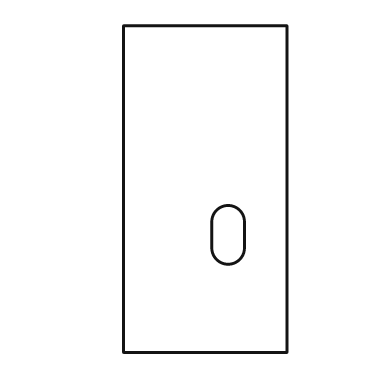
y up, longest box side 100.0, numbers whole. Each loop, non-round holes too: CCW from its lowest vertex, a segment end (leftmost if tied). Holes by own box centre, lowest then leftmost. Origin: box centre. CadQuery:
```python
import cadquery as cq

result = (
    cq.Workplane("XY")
    .moveTo(-25.0, -50.0)
    .lineTo(25.0, -50.0)
    .lineTo(25.0, 50.0)
    .lineTo(-25.0, 50.0)
    .close()
    .moveTo(2.0, -18.0)
    .threePointArc((7.0, -23.0), (12.0, -18.0))
    .lineTo(12.0, -10.0)
    .threePointArc((7.0, -5.0), (2.0, -10.0))
    .close()
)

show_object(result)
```